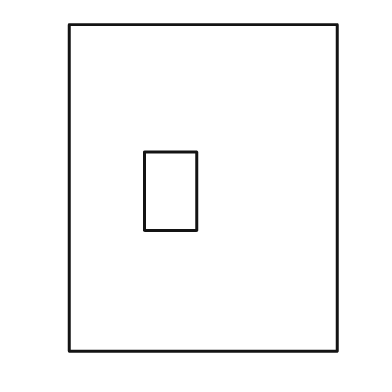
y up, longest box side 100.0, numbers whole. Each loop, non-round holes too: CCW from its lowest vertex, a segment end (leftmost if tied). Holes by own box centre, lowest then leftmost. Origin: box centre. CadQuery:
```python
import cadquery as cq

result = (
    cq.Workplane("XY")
    .moveTo(-41.0, -50.0)
    .lineTo(41.0, -50.0)
    .lineTo(41.0, 50.0)
    .lineTo(-41.0, 50.0)
    .close()
    .moveTo(-18.0, -13.0)
    .lineTo(-2.0, -13.0)
    .lineTo(-2.0, 11.0)
    .lineTo(-18.0, 11.0)
    .close()
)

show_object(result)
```